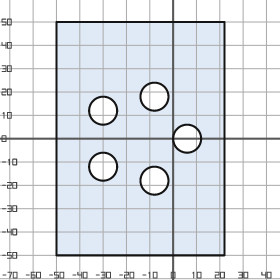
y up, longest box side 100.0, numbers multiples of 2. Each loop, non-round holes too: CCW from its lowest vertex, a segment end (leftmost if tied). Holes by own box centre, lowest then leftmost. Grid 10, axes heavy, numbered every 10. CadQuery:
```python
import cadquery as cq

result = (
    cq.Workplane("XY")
    .moveTo(-50.0, -50.0)
    .lineTo(22.0, -50.0)
    .lineTo(22.0, 50.0)
    .lineTo(-50.0, 50.0)
    .close()
    .moveTo(-8.0, -18.0)
    .circle(6.0)
    .moveTo(-30.0, -12.0)
    .circle(6.0)
    .moveTo(6.0, 0.0)
    .circle(6.0)
    .moveTo(-30.0, 12.0)
    .circle(6.0)
    .moveTo(-8.0, 18.0)
    .circle(6.0)
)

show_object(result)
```